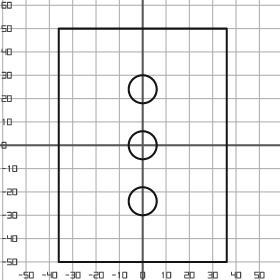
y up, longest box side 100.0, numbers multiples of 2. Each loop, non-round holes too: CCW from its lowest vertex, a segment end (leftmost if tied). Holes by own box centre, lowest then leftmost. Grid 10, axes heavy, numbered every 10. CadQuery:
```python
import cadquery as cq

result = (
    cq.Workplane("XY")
    .moveTo(-36.0, -50.0)
    .lineTo(36.0, -50.0)
    .lineTo(36.0, 50.0)
    .lineTo(-36.0, 50.0)
    .close()
    .moveTo(0.0, -24.0)
    .circle(6.0)
    .moveTo(0.0, 0.0)
    .circle(6.0)
    .moveTo(0.0, 24.0)
    .circle(6.0)
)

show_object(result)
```